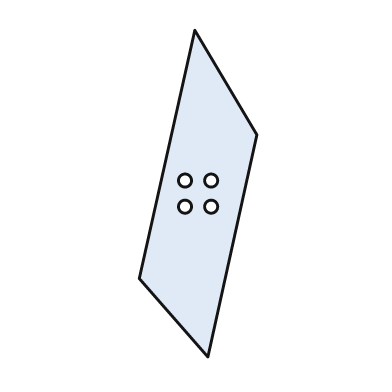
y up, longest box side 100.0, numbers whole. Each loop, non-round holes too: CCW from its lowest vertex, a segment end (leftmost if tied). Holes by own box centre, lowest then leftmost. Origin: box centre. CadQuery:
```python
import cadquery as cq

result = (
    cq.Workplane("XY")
    .moveTo(3.0, -50.0)
    .lineTo(18.0, 18.0)
    .lineTo(-1.0, 50.0)
    .lineTo(-18.0, -26.0)
    .close()
    .moveTo(-4.0, -4.0)
    .circle(2.0)
    .moveTo(4.0, -4.0)
    .circle(2.0)
    .moveTo(-4.0, 4.0)
    .circle(2.0)
    .moveTo(4.0, 4.0)
    .circle(2.0)
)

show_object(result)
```